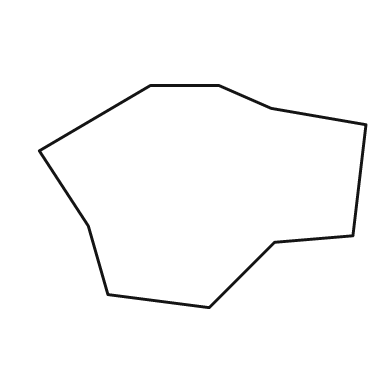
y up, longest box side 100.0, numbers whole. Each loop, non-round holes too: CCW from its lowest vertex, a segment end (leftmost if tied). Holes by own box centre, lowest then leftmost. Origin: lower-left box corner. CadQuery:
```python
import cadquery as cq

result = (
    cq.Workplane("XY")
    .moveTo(52.0, 0.0)
    .lineTo(72.0, 20.0)
    .lineTo(96.0, 22.0)
    .lineTo(100.0, 56.0)
    .lineTo(71.0, 61.0)
    .lineTo(55.0, 68.0)
    .lineTo(34.0, 68.0)
    .lineTo(0.0, 48.0)
    .lineTo(15.0, 25.0)
    .lineTo(21.0, 4.0)
    .close()
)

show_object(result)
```